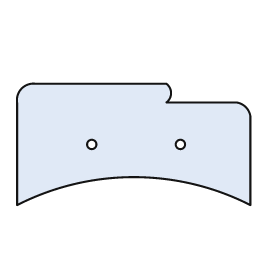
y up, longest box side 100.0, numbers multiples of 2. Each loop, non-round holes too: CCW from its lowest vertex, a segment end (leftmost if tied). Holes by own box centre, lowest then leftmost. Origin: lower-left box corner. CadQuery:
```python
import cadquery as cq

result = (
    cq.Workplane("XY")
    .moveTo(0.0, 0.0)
    .threePointArc((50.0, 12.0), (100.0, 0.0))
    .lineTo(100.0, 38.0)
    .threePointArc((98.0, 42.0), (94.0, 44.0))
    .lineTo(64.0, 44.0)
    .threePointArc((66.0, 48.0), (64.0, 52.0))
    .lineTo(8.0, 52.0)
    .threePointArc((2.0, 50.0), (0.0, 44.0))
    .close()
    .moveTo(32.0, 26.0)
    .circle(2.0)
    .moveTo(70.0, 26.0)
    .circle(2.0)
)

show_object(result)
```